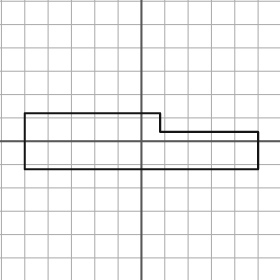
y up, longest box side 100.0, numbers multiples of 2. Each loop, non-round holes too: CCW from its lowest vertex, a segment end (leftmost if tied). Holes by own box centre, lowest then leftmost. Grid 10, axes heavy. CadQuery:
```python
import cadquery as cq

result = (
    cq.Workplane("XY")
    .moveTo(-50.0, -12.0)
    .lineTo(50.0, -12.0)
    .lineTo(50.0, 4.0)
    .lineTo(8.0, 4.0)
    .lineTo(8.0, 12.0)
    .lineTo(-50.0, 12.0)
    .close()
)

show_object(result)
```